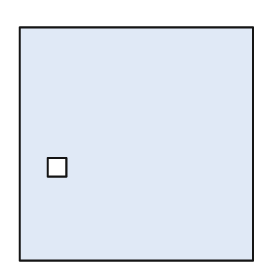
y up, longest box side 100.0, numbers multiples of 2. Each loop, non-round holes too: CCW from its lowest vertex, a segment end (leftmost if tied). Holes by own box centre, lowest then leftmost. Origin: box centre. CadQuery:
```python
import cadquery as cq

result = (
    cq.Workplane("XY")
    .moveTo(-50.0, -50.0)
    .lineTo(50.0, -50.0)
    .lineTo(50.0, 50.0)
    .lineTo(-50.0, 50.0)
    .close()
    .moveTo(-38.0, -14.0)
    .lineTo(-30.0, -14.0)
    .lineTo(-30.0, -6.0)
    .lineTo(-38.0, -6.0)
    .close()
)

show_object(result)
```